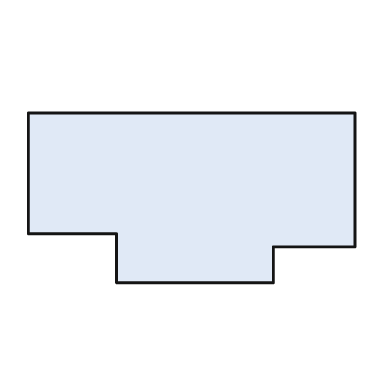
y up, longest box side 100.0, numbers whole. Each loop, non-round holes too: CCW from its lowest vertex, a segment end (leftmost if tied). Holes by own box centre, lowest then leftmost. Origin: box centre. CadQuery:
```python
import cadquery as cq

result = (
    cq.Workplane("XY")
    .moveTo(-23.0, -26.0)
    .lineTo(25.0, -26.0)
    .lineTo(25.0, -15.0)
    .lineTo(50.0, -15.0)
    .lineTo(50.0, 26.0)
    .lineTo(-50.0, 26.0)
    .lineTo(-50.0, -11.0)
    .lineTo(-23.0, -11.0)
    .close()
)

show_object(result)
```